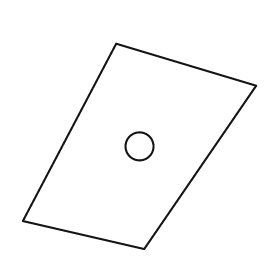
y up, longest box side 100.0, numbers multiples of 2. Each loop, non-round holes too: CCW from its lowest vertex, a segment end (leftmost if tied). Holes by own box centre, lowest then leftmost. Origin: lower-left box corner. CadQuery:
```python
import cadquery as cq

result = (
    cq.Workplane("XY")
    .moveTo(52.0, 0.0)
    .lineTo(100.0, 70.0)
    .lineTo(40.0, 88.0)
    .lineTo(0.0, 12.0)
    .close()
    .moveTo(50.0, 44.0)
    .circle(6.0)
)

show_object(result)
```